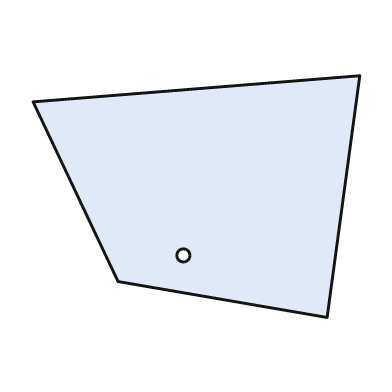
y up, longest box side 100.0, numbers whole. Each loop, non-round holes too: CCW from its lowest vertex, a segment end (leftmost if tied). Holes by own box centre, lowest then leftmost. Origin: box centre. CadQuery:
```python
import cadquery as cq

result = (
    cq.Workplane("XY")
    .moveTo(40.0, -37.0)
    .lineTo(50.0, 37.0)
    .lineTo(-50.0, 29.0)
    .lineTo(-24.0, -26.0)
    .close()
    .moveTo(-4.0, -18.0)
    .circle(2.0)
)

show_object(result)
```